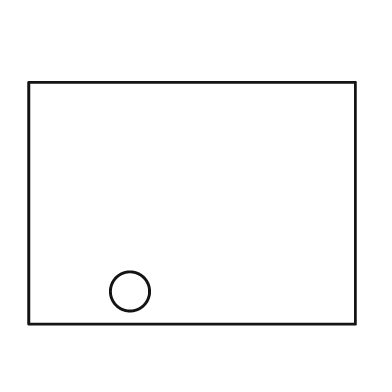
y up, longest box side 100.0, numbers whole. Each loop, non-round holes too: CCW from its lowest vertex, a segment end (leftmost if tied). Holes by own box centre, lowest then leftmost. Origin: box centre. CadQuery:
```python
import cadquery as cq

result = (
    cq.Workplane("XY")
    .moveTo(-50.0, -37.0)
    .lineTo(50.0, -37.0)
    .lineTo(50.0, 37.0)
    .lineTo(-50.0, 37.0)
    .close()
    .moveTo(-19.0, -27.0)
    .circle(6.0)
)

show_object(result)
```